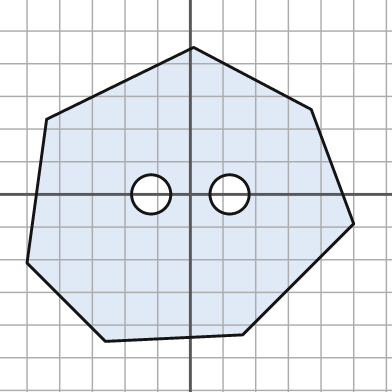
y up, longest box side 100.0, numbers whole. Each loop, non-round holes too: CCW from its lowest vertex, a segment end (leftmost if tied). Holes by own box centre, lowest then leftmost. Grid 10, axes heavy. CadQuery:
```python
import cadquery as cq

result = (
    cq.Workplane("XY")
    .moveTo(-26.0, -45.0)
    .lineTo(16.0, -43.0)
    .lineTo(50.0, -9.0)
    .lineTo(37.0, 26.0)
    .lineTo(1.0, 45.0)
    .lineTo(-44.0, 23.0)
    .lineTo(-50.0, -21.0)
    .close()
    .moveTo(-12.0, 0.0)
    .circle(6.0)
    .moveTo(12.0, 0.0)
    .circle(6.0)
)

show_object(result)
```